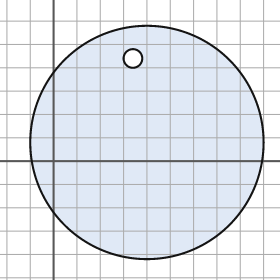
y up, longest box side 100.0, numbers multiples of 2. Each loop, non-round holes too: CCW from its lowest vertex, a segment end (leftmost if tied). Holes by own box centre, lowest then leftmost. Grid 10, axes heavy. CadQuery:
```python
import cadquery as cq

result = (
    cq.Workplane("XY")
    .moveTo(40.0, 8.0)
    .circle(50.0)
    .moveTo(34.0, 44.0)
    .circle(4.0)
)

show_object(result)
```